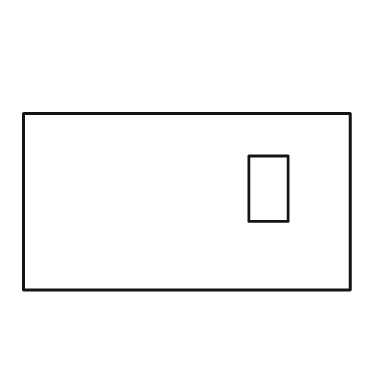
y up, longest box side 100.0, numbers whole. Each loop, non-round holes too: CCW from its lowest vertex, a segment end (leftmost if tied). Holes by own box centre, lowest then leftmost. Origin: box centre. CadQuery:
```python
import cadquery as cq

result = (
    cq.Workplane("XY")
    .moveTo(-50.0, -27.0)
    .lineTo(50.0, -27.0)
    .lineTo(50.0, 27.0)
    .lineTo(-50.0, 27.0)
    .close()
    .moveTo(19.0, -6.0)
    .lineTo(31.0, -6.0)
    .lineTo(31.0, 14.0)
    .lineTo(19.0, 14.0)
    .close()
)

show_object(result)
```